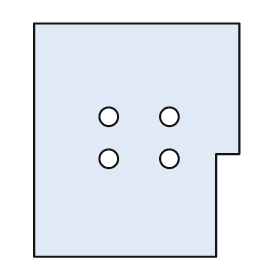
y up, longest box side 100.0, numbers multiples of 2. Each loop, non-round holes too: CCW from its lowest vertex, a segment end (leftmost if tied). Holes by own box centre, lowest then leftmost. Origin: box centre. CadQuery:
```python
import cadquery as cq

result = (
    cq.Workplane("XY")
    .moveTo(-44.0, -50.0)
    .lineTo(34.0, -50.0)
    .lineTo(34.0, -6.0)
    .lineTo(44.0, -6.0)
    .lineTo(44.0, 50.0)
    .lineTo(-44.0, 50.0)
    .close()
    .moveTo(-12.0, -8.0)
    .circle(4.0)
    .moveTo(14.0, -8.0)
    .circle(4.0)
    .moveTo(-12.0, 10.0)
    .circle(4.0)
    .moveTo(14.0, 10.0)
    .circle(4.0)
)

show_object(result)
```